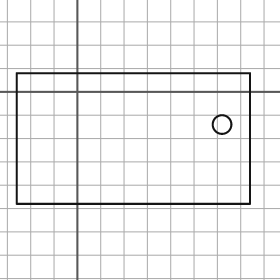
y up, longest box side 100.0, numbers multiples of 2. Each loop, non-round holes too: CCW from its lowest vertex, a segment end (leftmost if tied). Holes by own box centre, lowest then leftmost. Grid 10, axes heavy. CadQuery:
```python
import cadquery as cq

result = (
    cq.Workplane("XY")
    .moveTo(-26.0, -48.0)
    .lineTo(74.0, -48.0)
    .lineTo(74.0, 8.0)
    .lineTo(-26.0, 8.0)
    .close()
    .moveTo(62.0, -14.0)
    .circle(4.0)
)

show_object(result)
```